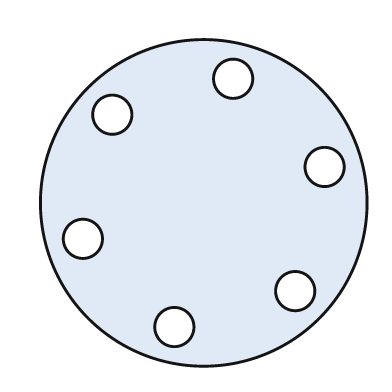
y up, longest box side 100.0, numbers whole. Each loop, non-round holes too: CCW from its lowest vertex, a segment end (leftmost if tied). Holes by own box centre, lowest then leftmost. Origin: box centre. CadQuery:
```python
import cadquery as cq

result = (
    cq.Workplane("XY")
    .moveTo(0.0, 0.0)
    .circle(50.0)
    .moveTo(-9.0, -38.0)
    .circle(6.0)
    .moveTo(28.0, -27.0)
    .circle(6.0)
    .moveTo(-37.0, -11.0)
    .circle(6.0)
    .moveTo(37.0, 11.0)
    .circle(6.0)
    .moveTo(-28.0, 27.0)
    .circle(6.0)
    .moveTo(9.0, 38.0)
    .circle(6.0)
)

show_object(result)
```